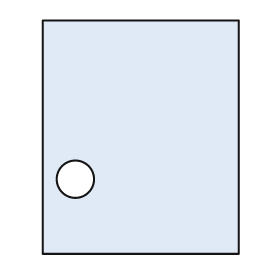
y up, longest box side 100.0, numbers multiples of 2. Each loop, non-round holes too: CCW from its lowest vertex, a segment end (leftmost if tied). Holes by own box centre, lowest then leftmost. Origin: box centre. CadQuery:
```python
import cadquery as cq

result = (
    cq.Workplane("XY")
    .moveTo(-42.0, -50.0)
    .lineTo(42.0, -50.0)
    .lineTo(42.0, 50.0)
    .lineTo(-42.0, 50.0)
    .close()
    .moveTo(-28.0, -18.0)
    .circle(8.0)
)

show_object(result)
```